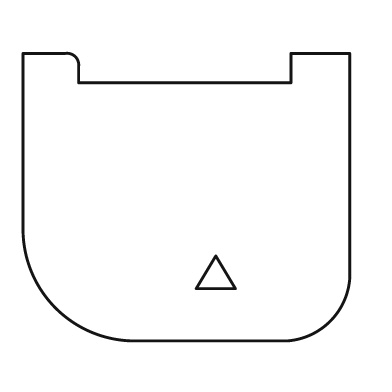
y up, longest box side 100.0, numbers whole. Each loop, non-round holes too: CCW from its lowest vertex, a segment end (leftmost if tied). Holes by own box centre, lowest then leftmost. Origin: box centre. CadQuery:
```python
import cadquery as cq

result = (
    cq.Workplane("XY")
    .moveTo(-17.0, -44.0)
    .lineTo(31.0, -44.0)
    .threePointArc((44.0, -38.0), (50.0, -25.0))
    .lineTo(50.0, 44.0)
    .lineTo(32.0, 44.0)
    .lineTo(32.0, 35.0)
    .lineTo(-33.0, 35.0)
    .lineTo(-33.0, 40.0)
    .threePointArc((-34.0, 43.0), (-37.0, 44.0))
    .lineTo(-50.0, 44.0)
    .lineTo(-50.0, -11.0)
    .threePointArc((-40.0, -34.0), (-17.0, -44.0))
    .close()
    .moveTo(3.0, -28.0)
    .lineTo(15.0, -28.0)
    .lineTo(9.0, -18.0)
    .close()
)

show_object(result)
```